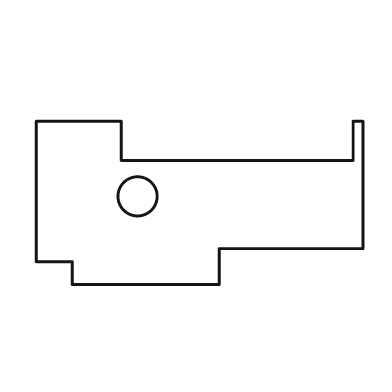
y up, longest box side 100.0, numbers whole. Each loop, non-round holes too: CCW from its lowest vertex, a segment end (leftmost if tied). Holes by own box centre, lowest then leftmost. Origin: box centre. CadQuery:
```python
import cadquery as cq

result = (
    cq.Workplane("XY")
    .moveTo(-39.0, -25.0)
    .lineTo(6.0, -25.0)
    .lineTo(6.0, -14.0)
    .lineTo(50.0, -14.0)
    .lineTo(50.0, 25.0)
    .lineTo(47.0, 25.0)
    .lineTo(47.0, 13.0)
    .lineTo(-24.0, 13.0)
    .lineTo(-24.0, 25.0)
    .lineTo(-50.0, 25.0)
    .lineTo(-50.0, -18.0)
    .lineTo(-39.0, -18.0)
    .close()
    .moveTo(-19.0, 2.0)
    .circle(6.0)
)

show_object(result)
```